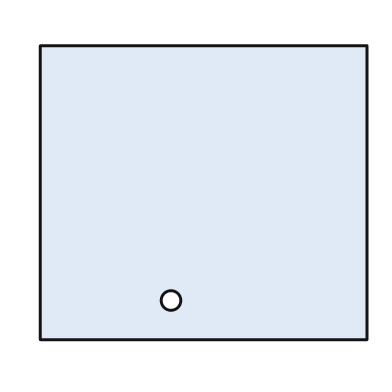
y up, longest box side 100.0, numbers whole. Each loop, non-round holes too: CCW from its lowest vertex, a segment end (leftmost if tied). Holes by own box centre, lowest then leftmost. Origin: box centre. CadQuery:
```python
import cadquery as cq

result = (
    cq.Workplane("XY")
    .moveTo(-50.0, -45.0)
    .lineTo(50.0, -45.0)
    .lineTo(50.0, 45.0)
    .lineTo(-50.0, 45.0)
    .close()
    .moveTo(-10.0, -33.0)
    .circle(3.0)
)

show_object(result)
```